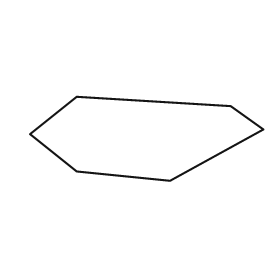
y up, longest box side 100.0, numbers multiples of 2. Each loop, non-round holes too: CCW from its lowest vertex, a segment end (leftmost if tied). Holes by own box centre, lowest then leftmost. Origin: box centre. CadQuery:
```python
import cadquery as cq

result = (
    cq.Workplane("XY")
    .moveTo(10.0, -18.0)
    .lineTo(50.0, 4.0)
    .lineTo(36.0, 14.0)
    .lineTo(-30.0, 18.0)
    .lineTo(-50.0, 2.0)
    .lineTo(-30.0, -14.0)
    .close()
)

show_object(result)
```